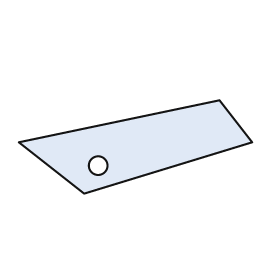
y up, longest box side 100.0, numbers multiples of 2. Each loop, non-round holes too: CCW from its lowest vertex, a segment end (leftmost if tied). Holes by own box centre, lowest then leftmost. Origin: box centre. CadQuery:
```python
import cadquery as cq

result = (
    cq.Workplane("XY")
    .moveTo(-22.0, -20.0)
    .lineTo(50.0, 2.0)
    .lineTo(36.0, 20.0)
    .lineTo(-50.0, 2.0)
    .close()
    .moveTo(-16.0, -8.0)
    .circle(4.0)
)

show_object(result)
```